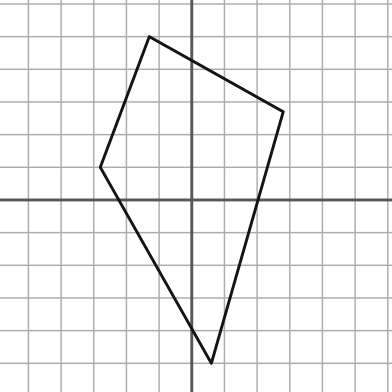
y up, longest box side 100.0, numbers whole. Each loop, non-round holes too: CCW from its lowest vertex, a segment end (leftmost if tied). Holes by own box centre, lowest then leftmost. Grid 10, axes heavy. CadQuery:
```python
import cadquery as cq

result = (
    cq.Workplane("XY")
    .moveTo(6.0, -50.0)
    .lineTo(28.0, 27.0)
    .lineTo(-13.0, 50.0)
    .lineTo(-28.0, 10.0)
    .close()
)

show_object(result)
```